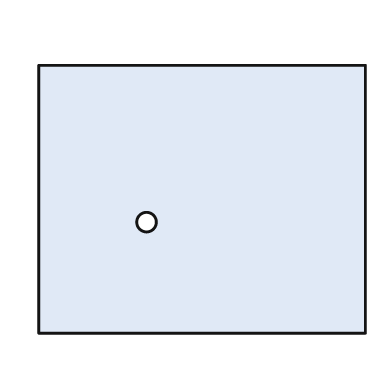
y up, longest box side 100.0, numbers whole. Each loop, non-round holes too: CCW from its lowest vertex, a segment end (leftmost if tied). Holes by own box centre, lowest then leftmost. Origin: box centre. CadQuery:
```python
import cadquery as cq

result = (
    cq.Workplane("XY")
    .moveTo(-50.0, -41.0)
    .lineTo(50.0, -41.0)
    .lineTo(50.0, 41.0)
    .lineTo(-50.0, 41.0)
    .close()
    .moveTo(-17.0, -7.0)
    .circle(3.0)
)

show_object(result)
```